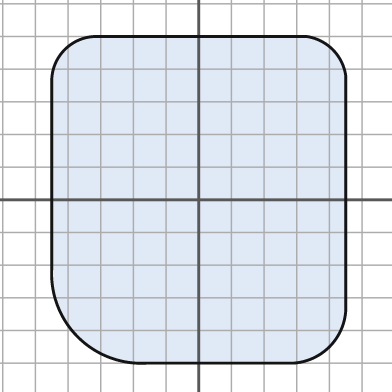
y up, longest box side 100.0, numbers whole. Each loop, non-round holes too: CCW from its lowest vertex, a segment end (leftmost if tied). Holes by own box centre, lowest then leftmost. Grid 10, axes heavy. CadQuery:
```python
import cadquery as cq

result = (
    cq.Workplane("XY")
    .moveTo(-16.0, -50.0)
    .lineTo(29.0, -50.0)
    .threePointArc((40.0, -45.0), (45.0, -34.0))
    .lineTo(45.0, 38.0)
    .threePointArc((41.0, 46.0), (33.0, 50.0))
    .lineTo(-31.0, 50.0)
    .threePointArc((-41.0, 46.0), (-45.0, 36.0))
    .lineTo(-45.0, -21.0)
    .threePointArc((-37.0, -42.0), (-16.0, -50.0))
    .close()
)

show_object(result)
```